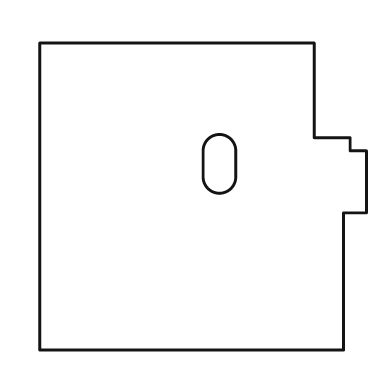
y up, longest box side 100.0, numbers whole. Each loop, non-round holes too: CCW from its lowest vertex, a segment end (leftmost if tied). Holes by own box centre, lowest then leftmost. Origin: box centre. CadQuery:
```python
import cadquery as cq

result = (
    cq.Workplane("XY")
    .moveTo(-50.0, -47.0)
    .lineTo(43.0, -47.0)
    .lineTo(43.0, -5.0)
    .lineTo(50.0, -5.0)
    .lineTo(50.0, 14.0)
    .lineTo(45.0, 14.0)
    .lineTo(45.0, 18.0)
    .lineTo(34.0, 18.0)
    .lineTo(34.0, 47.0)
    .lineTo(-50.0, 47.0)
    .close()
    .moveTo(0.0, 6.0)
    .threePointArc((5.0, 1.0), (10.0, 6.0))
    .lineTo(10.0, 14.0)
    .threePointArc((5.0, 19.0), (0.0, 14.0))
    .close()
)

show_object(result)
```